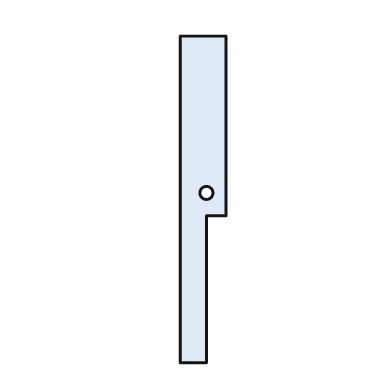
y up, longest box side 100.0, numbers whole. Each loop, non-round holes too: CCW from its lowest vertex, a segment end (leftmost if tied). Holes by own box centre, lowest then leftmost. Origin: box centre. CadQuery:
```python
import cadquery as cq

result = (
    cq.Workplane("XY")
    .moveTo(-7.0, -50.0)
    .lineTo(1.0, -50.0)
    .lineTo(1.0, -5.0)
    .lineTo(7.0, -5.0)
    .lineTo(7.0, 50.0)
    .lineTo(-7.0, 50.0)
    .close()
    .moveTo(1.0, 2.0)
    .circle(2.0)
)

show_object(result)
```